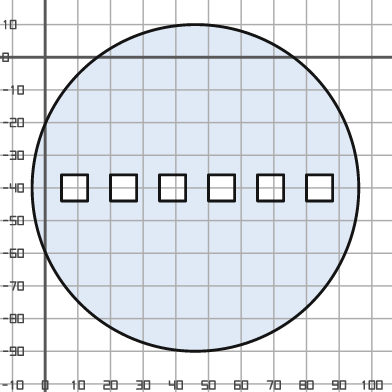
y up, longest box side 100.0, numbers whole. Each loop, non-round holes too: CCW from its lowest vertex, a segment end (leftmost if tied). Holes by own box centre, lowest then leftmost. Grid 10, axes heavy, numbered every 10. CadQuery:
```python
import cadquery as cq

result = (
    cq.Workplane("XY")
    .moveTo(46.0, -40.0)
    .circle(50.0)
    .moveTo(5.0, -44.0)
    .lineTo(13.0, -44.0)
    .lineTo(13.0, -36.0)
    .lineTo(5.0, -36.0)
    .close()
    .moveTo(20.0, -44.0)
    .lineTo(28.0, -44.0)
    .lineTo(28.0, -36.0)
    .lineTo(20.0, -36.0)
    .close()
    .moveTo(35.0, -44.0)
    .lineTo(43.0, -44.0)
    .lineTo(43.0, -36.0)
    .lineTo(35.0, -36.0)
    .close()
    .moveTo(50.0, -44.0)
    .lineTo(58.0, -44.0)
    .lineTo(58.0, -36.0)
    .lineTo(50.0, -36.0)
    .close()
    .moveTo(65.0, -44.0)
    .lineTo(73.0, -44.0)
    .lineTo(73.0, -36.0)
    .lineTo(65.0, -36.0)
    .close()
    .moveTo(80.0, -44.0)
    .lineTo(88.0, -44.0)
    .lineTo(88.0, -36.0)
    .lineTo(80.0, -36.0)
    .close()
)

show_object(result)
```